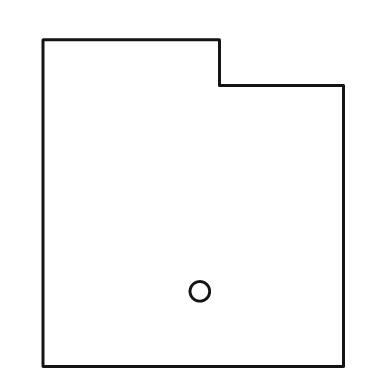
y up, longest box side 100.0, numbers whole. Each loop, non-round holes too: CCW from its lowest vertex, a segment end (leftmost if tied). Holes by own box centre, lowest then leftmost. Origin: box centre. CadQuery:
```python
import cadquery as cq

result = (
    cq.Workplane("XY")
    .moveTo(-46.0, -50.0)
    .lineTo(46.0, -50.0)
    .lineTo(46.0, 36.0)
    .lineTo(8.0, 36.0)
    .lineTo(8.0, 50.0)
    .lineTo(-46.0, 50.0)
    .close()
    .moveTo(2.0, -27.0)
    .circle(3.0)
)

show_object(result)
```